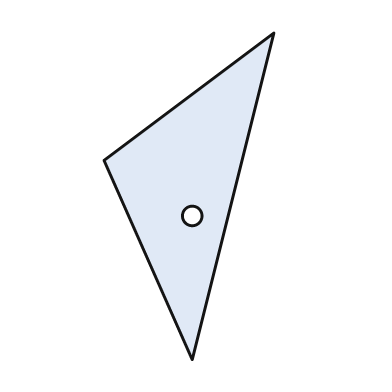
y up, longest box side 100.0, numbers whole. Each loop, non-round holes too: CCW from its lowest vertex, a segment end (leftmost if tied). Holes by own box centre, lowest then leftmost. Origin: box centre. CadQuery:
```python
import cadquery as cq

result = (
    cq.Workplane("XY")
    .moveTo(1.0, -50.0)
    .lineTo(26.0, 50.0)
    .lineTo(-26.0, 11.0)
    .close()
    .moveTo(1.0, -6.0)
    .circle(3.0)
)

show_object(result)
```